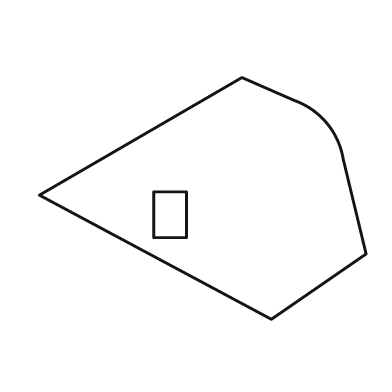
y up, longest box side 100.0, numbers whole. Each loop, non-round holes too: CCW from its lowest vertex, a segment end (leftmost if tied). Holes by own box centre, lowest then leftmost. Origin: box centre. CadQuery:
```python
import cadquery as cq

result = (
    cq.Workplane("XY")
    .moveTo(21.0, -37.0)
    .lineTo(50.0, -17.0)
    .lineTo(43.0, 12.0)
    .threePointArc((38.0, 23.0), (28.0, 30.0))
    .lineTo(12.0, 37.0)
    .lineTo(-50.0, 1.0)
    .close()
    .moveTo(-15.0, -12.0)
    .lineTo(-5.0, -12.0)
    .lineTo(-5.0, 2.0)
    .lineTo(-15.0, 2.0)
    .close()
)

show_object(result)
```